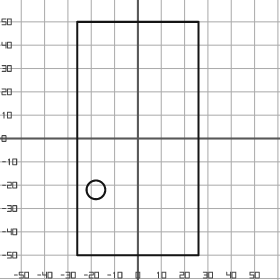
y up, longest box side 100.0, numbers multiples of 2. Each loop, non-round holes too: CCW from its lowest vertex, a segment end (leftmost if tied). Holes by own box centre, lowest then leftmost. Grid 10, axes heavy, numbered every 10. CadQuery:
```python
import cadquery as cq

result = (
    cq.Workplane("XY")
    .moveTo(-26.0, -50.0)
    .lineTo(26.0, -50.0)
    .lineTo(26.0, 50.0)
    .lineTo(-26.0, 50.0)
    .close()
    .moveTo(-18.0, -22.0)
    .circle(4.0)
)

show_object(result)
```